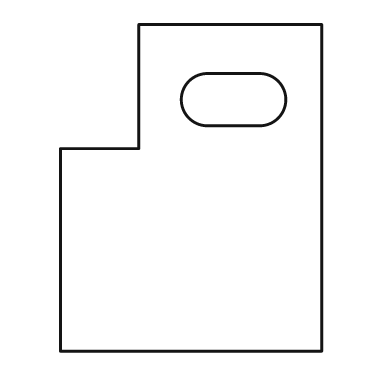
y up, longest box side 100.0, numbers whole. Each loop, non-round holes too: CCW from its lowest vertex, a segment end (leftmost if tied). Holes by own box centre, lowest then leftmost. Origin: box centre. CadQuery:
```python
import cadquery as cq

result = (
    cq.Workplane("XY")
    .moveTo(-40.0, -50.0)
    .lineTo(40.0, -50.0)
    .lineTo(40.0, 50.0)
    .lineTo(-16.0, 50.0)
    .lineTo(-16.0, 12.0)
    .lineTo(-40.0, 12.0)
    .close()
    .moveTo(5.0, 19.0)
    .lineTo(21.0, 19.0)
    .threePointArc((29.0, 27.0), (21.0, 35.0))
    .lineTo(5.0, 35.0)
    .threePointArc((-3.0, 27.0), (5.0, 19.0))
    .close()
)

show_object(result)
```